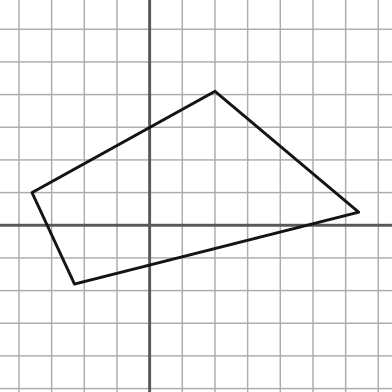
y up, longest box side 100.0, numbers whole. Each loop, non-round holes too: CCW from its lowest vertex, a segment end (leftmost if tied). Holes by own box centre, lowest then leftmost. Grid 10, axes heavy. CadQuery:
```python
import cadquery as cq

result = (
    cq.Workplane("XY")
    .moveTo(-23.0, -18.0)
    .lineTo(64.0, 4.0)
    .lineTo(20.0, 41.0)
    .lineTo(-36.0, 10.0)
    .close()
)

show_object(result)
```